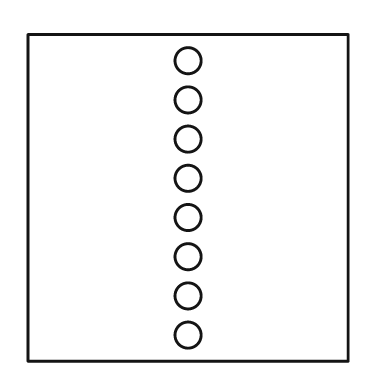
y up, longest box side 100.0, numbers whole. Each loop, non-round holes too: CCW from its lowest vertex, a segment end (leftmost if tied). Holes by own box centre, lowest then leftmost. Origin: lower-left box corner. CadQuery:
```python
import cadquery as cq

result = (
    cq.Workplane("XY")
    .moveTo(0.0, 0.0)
    .lineTo(98.0, 0.0)
    .lineTo(98.0, 100.0)
    .lineTo(0.0, 100.0)
    .close()
    .moveTo(49.0, 8.0)
    .circle(4.0)
    .moveTo(49.0, 20.0)
    .circle(4.0)
    .moveTo(49.0, 32.0)
    .circle(4.0)
    .moveTo(49.0, 44.0)
    .circle(4.0)
    .moveTo(49.0, 56.0)
    .circle(4.0)
    .moveTo(49.0, 68.0)
    .circle(4.0)
    .moveTo(49.0, 80.0)
    .circle(4.0)
    .moveTo(49.0, 92.0)
    .circle(4.0)
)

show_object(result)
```